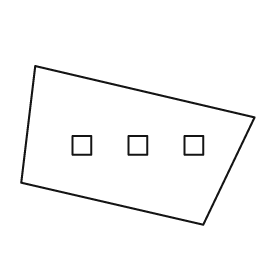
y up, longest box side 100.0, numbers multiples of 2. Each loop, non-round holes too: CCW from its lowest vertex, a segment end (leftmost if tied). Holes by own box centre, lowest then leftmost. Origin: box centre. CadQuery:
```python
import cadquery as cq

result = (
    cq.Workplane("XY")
    .moveTo(28.0, -34.0)
    .lineTo(50.0, 12.0)
    .lineTo(-44.0, 34.0)
    .lineTo(-50.0, -16.0)
    .close()
    .moveTo(-28.0, -4.0)
    .lineTo(-20.0, -4.0)
    .lineTo(-20.0, 4.0)
    .lineTo(-28.0, 4.0)
    .close()
    .moveTo(-4.0, -4.0)
    .lineTo(4.0, -4.0)
    .lineTo(4.0, 4.0)
    .lineTo(-4.0, 4.0)
    .close()
    .moveTo(20.0, -4.0)
    .lineTo(28.0, -4.0)
    .lineTo(28.0, 4.0)
    .lineTo(20.0, 4.0)
    .close()
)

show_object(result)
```